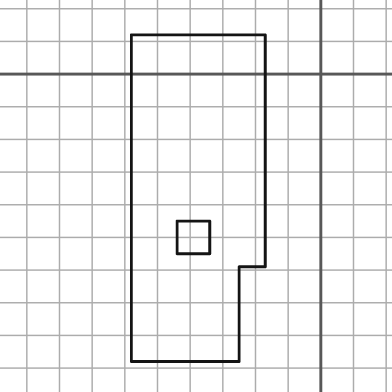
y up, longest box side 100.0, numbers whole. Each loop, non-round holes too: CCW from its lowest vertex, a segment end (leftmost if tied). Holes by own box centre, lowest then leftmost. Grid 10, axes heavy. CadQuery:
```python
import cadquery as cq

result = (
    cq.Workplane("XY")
    .moveTo(-58.0, -88.0)
    .lineTo(-25.0, -88.0)
    .lineTo(-25.0, -59.0)
    .lineTo(-17.0, -59.0)
    .lineTo(-17.0, 12.0)
    .lineTo(-58.0, 12.0)
    .close()
    .moveTo(-44.0, -55.0)
    .lineTo(-34.0, -55.0)
    .lineTo(-34.0, -45.0)
    .lineTo(-44.0, -45.0)
    .close()
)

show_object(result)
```